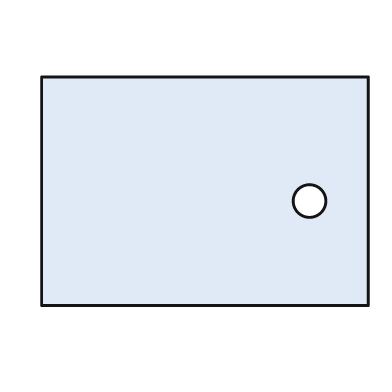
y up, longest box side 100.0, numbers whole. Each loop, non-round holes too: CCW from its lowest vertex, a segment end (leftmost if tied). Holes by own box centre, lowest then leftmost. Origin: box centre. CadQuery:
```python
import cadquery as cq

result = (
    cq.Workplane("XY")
    .moveTo(-50.0, -35.0)
    .lineTo(50.0, -35.0)
    .lineTo(50.0, 35.0)
    .lineTo(-50.0, 35.0)
    .close()
    .moveTo(32.0, -3.0)
    .circle(5.0)
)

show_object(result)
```